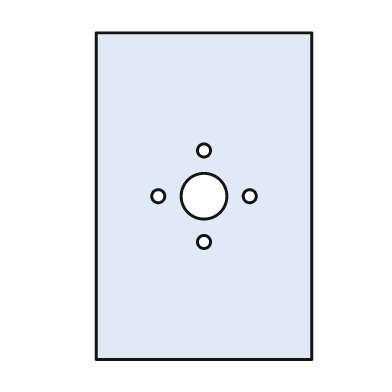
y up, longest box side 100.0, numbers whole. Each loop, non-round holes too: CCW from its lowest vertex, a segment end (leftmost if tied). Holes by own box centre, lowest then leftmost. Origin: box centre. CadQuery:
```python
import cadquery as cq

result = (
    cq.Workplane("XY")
    .moveTo(-33.0, -50.0)
    .lineTo(33.0, -50.0)
    .lineTo(33.0, 50.0)
    .lineTo(-33.0, 50.0)
    .close()
    .moveTo(0.0, -14.0)
    .circle(2.0)
    .moveTo(-14.0, 0.0)
    .circle(2.0)
    .moveTo(0.0, 0.0)
    .circle(7.0)
    .moveTo(14.0, 0.0)
    .circle(2.0)
    .moveTo(0.0, 14.0)
    .circle(2.0)
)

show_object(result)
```